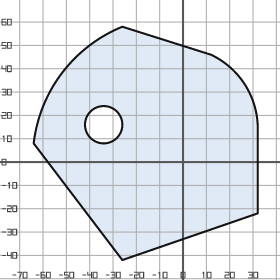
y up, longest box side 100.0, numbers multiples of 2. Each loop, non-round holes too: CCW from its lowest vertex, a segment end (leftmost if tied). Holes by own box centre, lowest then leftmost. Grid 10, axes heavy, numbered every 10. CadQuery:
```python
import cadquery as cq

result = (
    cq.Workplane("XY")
    .moveTo(-26.0, -42.0)
    .lineTo(32.0, -22.0)
    .lineTo(32.0, 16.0)
    .threePointArc((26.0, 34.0), (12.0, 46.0))
    .lineTo(-26.0, 58.0)
    .threePointArc((-52.0, 38.0), (-64.0, 8.0))
    .close()
    .moveTo(-34.0, 16.0)
    .circle(8.0)
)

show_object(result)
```